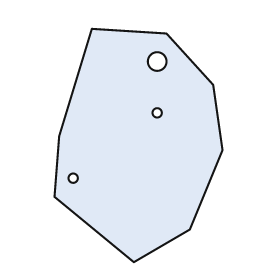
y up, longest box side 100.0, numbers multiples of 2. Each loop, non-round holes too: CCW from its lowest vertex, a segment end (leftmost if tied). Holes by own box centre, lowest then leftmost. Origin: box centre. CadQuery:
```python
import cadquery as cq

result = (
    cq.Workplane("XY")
    .moveTo(-2.0, -50.0)
    .lineTo(22.0, -36.0)
    .lineTo(36.0, -2.0)
    .lineTo(32.0, 26.0)
    .lineTo(12.0, 48.0)
    .lineTo(-20.0, 50.0)
    .lineTo(-34.0, 4.0)
    .lineTo(-36.0, -22.0)
    .close()
    .moveTo(-28.0, -14.0)
    .circle(2.0)
    .moveTo(8.0, 14.0)
    .circle(2.0)
    .moveTo(8.0, 36.0)
    .circle(4.0)
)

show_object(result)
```